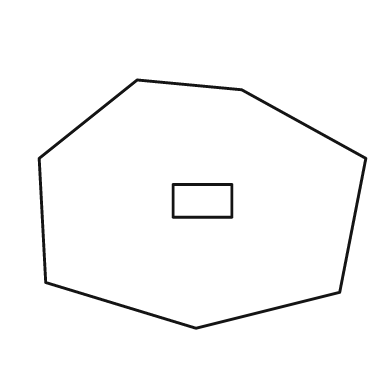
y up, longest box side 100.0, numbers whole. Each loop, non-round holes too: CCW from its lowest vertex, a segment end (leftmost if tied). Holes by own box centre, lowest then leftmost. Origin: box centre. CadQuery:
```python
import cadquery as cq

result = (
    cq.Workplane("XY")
    .moveTo(-2.0, -38.0)
    .lineTo(42.0, -27.0)
    .lineTo(50.0, 14.0)
    .lineTo(12.0, 35.0)
    .lineTo(-20.0, 38.0)
    .lineTo(-50.0, 14.0)
    .lineTo(-48.0, -24.0)
    .close()
    .moveTo(-9.0, -4.0)
    .lineTo(9.0, -4.0)
    .lineTo(9.0, 6.0)
    .lineTo(-9.0, 6.0)
    .close()
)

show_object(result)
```